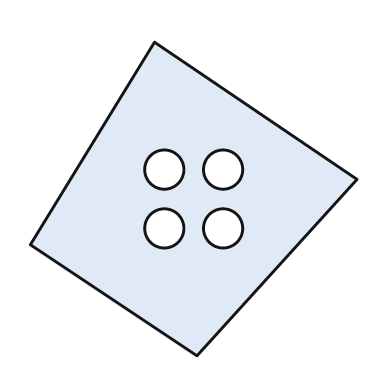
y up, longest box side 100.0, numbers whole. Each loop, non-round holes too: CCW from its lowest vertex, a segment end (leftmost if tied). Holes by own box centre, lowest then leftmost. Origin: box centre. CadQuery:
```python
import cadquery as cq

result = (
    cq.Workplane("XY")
    .moveTo(1.0, -48.0)
    .lineTo(50.0, 6.0)
    .lineTo(-12.0, 48.0)
    .lineTo(-50.0, -14.0)
    .close()
    .moveTo(-9.0, -9.0)
    .circle(6.0)
    .moveTo(9.0, -9.0)
    .circle(6.0)
    .moveTo(-9.0, 9.0)
    .circle(6.0)
    .moveTo(9.0, 9.0)
    .circle(6.0)
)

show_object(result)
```